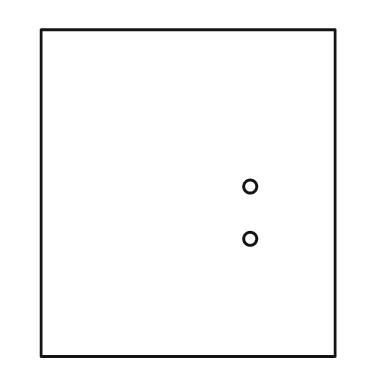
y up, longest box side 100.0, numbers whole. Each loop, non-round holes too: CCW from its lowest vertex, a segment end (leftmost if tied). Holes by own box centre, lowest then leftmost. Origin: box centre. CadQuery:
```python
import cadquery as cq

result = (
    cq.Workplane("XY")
    .moveTo(-45.0, -50.0)
    .lineTo(45.0, -50.0)
    .lineTo(45.0, 50.0)
    .lineTo(-45.0, 50.0)
    .close()
    .moveTo(19.0, -14.0)
    .circle(2.0)
    .moveTo(19.0, 2.0)
    .circle(2.0)
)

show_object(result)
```